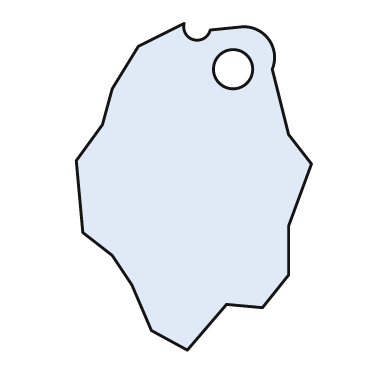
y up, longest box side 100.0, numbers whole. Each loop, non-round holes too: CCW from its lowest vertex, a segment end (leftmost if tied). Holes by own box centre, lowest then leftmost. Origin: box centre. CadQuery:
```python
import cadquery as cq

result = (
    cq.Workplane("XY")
    .moveTo(-2.0, -50.0)
    .lineTo(10.0, -36.0)
    .lineTo(21.0, -37.0)
    .lineTo(29.0, -27.0)
    .lineTo(29.0, -12.0)
    .lineTo(36.0, 7.0)
    .lineTo(29.0, 16.0)
    .lineTo(24.0, 36.0)
    .threePointArc((23.0, 45.0), (15.0, 49.0))
    .lineTo(5.0, 48.0)
    .threePointArc((0.0, 45.0), (-3.0, 50.0))
    .lineTo(-17.0, 43.0)
    .lineTo(-25.0, 30.0)
    .lineTo(-28.0, 19.0)
    .lineTo(-36.0, 8.0)
    .lineTo(-34.0, -14.0)
    .lineTo(-25.0, -21.0)
    .lineTo(-19.0, -30.0)
    .lineTo(-13.0, -44.0)
    .close()
    .moveTo(12.0, 36.0)
    .circle(6.0)
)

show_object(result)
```